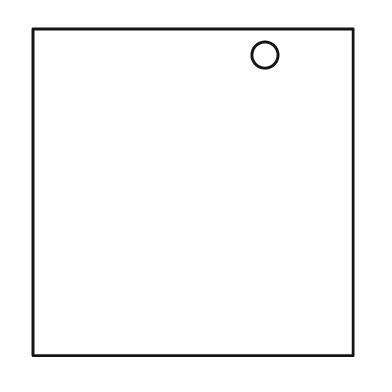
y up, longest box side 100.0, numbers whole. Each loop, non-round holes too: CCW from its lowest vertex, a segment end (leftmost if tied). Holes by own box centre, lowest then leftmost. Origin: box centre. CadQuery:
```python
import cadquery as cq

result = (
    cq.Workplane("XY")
    .moveTo(-49.0, -50.0)
    .lineTo(49.0, -50.0)
    .lineTo(49.0, 50.0)
    .lineTo(-49.0, 50.0)
    .close()
    .moveTo(22.0, 42.0)
    .circle(4.0)
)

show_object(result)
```